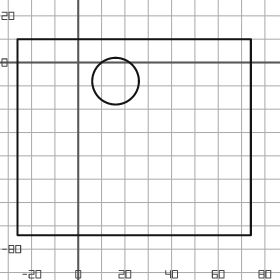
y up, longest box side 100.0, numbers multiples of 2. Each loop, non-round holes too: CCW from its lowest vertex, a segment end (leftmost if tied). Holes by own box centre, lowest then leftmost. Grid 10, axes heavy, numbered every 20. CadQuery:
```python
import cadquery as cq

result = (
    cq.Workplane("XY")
    .moveTo(-26.0, -74.0)
    .lineTo(74.0, -74.0)
    .lineTo(74.0, 10.0)
    .lineTo(-26.0, 10.0)
    .close()
    .moveTo(16.0, -8.0)
    .circle(10.0)
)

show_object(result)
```